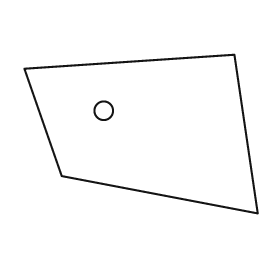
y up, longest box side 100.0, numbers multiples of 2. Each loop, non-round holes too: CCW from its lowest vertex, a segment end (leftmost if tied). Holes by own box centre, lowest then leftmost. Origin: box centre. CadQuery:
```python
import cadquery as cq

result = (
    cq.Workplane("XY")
    .moveTo(50.0, -34.0)
    .lineTo(40.0, 34.0)
    .lineTo(-50.0, 28.0)
    .lineTo(-34.0, -18.0)
    .close()
    .moveTo(-16.0, 10.0)
    .circle(4.0)
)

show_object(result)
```